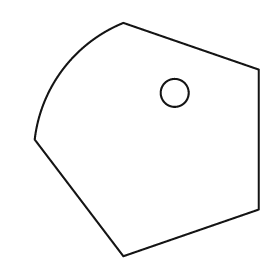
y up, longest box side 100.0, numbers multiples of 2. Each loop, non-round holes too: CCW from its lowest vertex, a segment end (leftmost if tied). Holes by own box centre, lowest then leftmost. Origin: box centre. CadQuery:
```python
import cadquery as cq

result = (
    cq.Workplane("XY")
    .moveTo(-10.0, -50.0)
    .lineTo(48.0, -30.0)
    .lineTo(48.0, 30.0)
    .lineTo(-10.0, 50.0)
    .threePointArc((-36.0, 30.0), (-48.0, 0.0))
    .close()
    .moveTo(12.0, 20.0)
    .circle(6.0)
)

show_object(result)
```